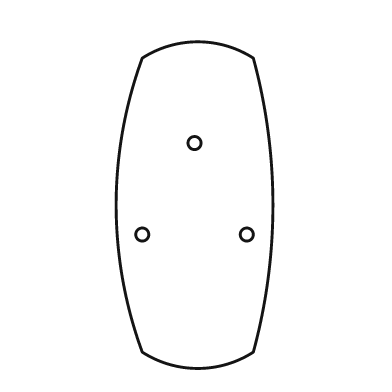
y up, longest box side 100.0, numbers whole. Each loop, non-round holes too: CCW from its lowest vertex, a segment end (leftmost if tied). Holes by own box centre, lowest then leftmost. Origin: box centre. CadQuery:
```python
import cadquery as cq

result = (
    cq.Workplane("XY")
    .moveTo(-16.0, -45.0)
    .threePointArc((1.0, -50.0), (18.0, -45.0))
    .threePointArc((24.0, 0.0), (18.0, 45.0))
    .threePointArc((1.0, 50.0), (-16.0, 45.0))
    .threePointArc((-24.0, 0.0), (-16.0, -45.0))
    .close()
    .moveTo(-16.0, -9.0)
    .circle(2.0)
    .moveTo(16.0, -9.0)
    .circle(2.0)
    .moveTo(0.0, 19.0)
    .circle(2.0)
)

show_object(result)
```